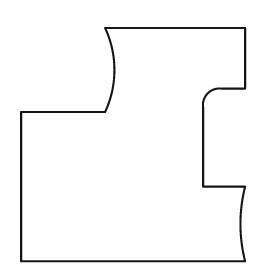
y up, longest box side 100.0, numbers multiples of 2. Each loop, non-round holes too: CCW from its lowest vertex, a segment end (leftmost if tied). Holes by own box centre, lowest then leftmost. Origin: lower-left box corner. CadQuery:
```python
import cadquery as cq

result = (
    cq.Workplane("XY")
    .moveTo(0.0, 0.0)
    .lineTo(96.0, 0.0)
    .threePointArc((94.0, 16.0), (96.0, 32.0))
    .lineTo(78.0, 32.0)
    .lineTo(78.0, 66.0)
    .threePointArc((80.0, 72.0), (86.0, 74.0))
    .lineTo(96.0, 74.0)
    .lineTo(96.0, 100.0)
    .lineTo(36.0, 100.0)
    .threePointArc((40.0, 82.0), (36.0, 64.0))
    .lineTo(0.0, 64.0)
    .close()
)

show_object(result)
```